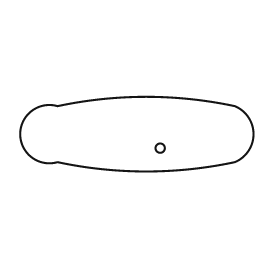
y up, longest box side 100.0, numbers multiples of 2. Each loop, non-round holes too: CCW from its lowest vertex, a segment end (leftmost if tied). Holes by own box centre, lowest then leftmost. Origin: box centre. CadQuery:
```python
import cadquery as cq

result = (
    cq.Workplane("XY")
    .moveTo(-34.0, -12.0)
    .threePointArc((4.0, -16.0), (42.0, -12.0))
    .threePointArc((50.0, 0.0), (42.0, 12.0))
    .threePointArc((4.0, 16.0), (-34.0, 12.0))
    .threePointArc((-50.0, 0.0), (-34.0, -12.0))
    .close()
    .moveTo(10.0, -6.0)
    .circle(2.0)
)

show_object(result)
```